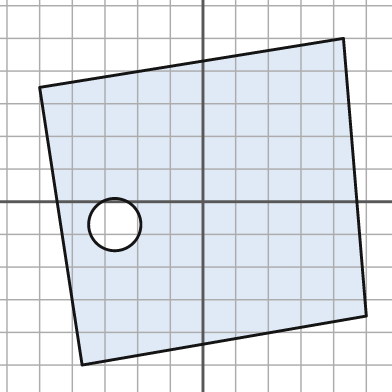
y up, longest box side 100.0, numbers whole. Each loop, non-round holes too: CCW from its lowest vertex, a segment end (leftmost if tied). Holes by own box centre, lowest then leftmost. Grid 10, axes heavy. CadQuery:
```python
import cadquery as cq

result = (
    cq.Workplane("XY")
    .moveTo(-37.0, -50.0)
    .lineTo(50.0, -35.0)
    .lineTo(43.0, 50.0)
    .lineTo(-50.0, 35.0)
    .close()
    .moveTo(-27.0, -7.0)
    .circle(8.0)
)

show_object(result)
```